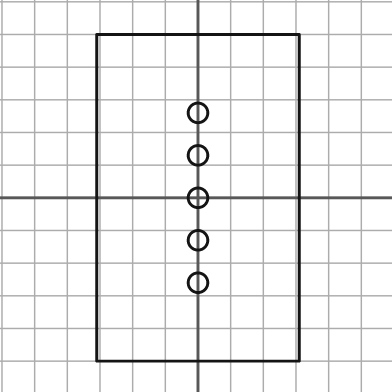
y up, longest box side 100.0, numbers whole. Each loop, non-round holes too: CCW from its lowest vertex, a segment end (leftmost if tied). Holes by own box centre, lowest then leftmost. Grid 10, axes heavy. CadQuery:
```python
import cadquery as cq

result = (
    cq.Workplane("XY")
    .moveTo(-31.0, -50.0)
    .lineTo(31.0, -50.0)
    .lineTo(31.0, 50.0)
    .lineTo(-31.0, 50.0)
    .close()
    .moveTo(0.0, -26.0)
    .circle(3.0)
    .moveTo(0.0, -13.0)
    .circle(3.0)
    .moveTo(0.0, 0.0)
    .circle(3.0)
    .moveTo(0.0, 13.0)
    .circle(3.0)
    .moveTo(0.0, 26.0)
    .circle(3.0)
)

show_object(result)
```